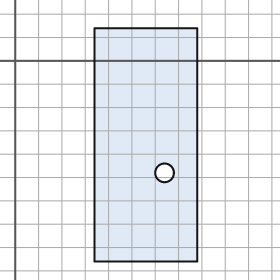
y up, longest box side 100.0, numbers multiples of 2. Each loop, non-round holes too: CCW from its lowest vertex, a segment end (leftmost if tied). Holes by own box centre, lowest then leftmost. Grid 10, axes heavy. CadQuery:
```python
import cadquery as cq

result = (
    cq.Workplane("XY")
    .moveTo(34.0, -86.0)
    .lineTo(78.0, -86.0)
    .lineTo(78.0, 14.0)
    .lineTo(34.0, 14.0)
    .close()
    .moveTo(64.0, -48.0)
    .circle(4.0)
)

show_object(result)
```